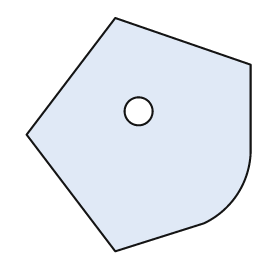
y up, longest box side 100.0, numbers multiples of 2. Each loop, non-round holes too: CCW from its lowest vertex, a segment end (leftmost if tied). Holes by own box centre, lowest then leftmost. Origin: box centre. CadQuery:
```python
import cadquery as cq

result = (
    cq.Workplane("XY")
    .moveTo(-10.0, -50.0)
    .lineTo(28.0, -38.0)
    .threePointArc((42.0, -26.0), (48.0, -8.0))
    .lineTo(48.0, 30.0)
    .lineTo(-10.0, 50.0)
    .lineTo(-48.0, 0.0)
    .close()
    .moveTo(0.0, 10.0)
    .circle(6.0)
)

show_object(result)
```